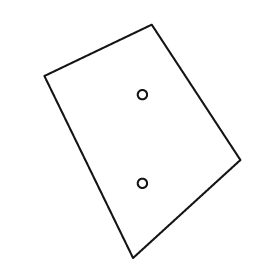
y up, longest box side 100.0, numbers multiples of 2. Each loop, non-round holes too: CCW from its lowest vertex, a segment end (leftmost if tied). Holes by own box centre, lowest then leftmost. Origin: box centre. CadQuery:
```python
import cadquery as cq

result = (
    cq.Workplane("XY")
    .moveTo(-4.0, -50.0)
    .lineTo(42.0, -8.0)
    .lineTo(4.0, 50.0)
    .lineTo(-42.0, 28.0)
    .close()
    .moveTo(0.0, -18.0)
    .circle(2.0)
    .moveTo(0.0, 20.0)
    .circle(2.0)
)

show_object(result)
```